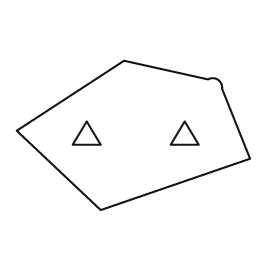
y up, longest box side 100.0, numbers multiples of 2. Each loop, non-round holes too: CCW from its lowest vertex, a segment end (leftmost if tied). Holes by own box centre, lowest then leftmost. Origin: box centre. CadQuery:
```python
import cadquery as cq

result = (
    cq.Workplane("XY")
    .moveTo(-14.0, -32.0)
    .lineTo(50.0, -10.0)
    .lineTo(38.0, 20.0)
    .threePointArc((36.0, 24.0), (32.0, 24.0))
    .lineTo(-4.0, 32.0)
    .lineTo(-50.0, 2.0)
    .close()
    .moveTo(-26.0, -4.0)
    .lineTo(-14.0, -4.0)
    .lineTo(-20.0, 6.0)
    .close()
    .moveTo(16.0, -4.0)
    .lineTo(28.0, -4.0)
    .lineTo(22.0, 6.0)
    .close()
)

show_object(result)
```